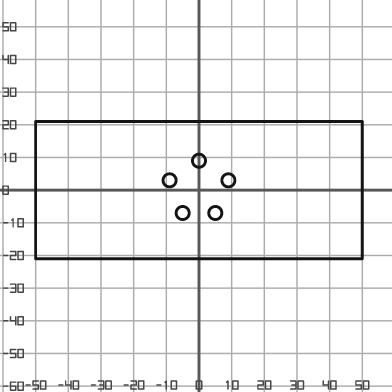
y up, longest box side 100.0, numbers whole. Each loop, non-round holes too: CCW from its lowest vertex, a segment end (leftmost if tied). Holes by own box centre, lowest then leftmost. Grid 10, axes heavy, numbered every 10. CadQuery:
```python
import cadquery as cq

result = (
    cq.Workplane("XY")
    .moveTo(-50.0, -21.0)
    .lineTo(50.0, -21.0)
    .lineTo(50.0, 21.0)
    .lineTo(-50.0, 21.0)
    .close()
    .moveTo(-5.0, -7.0)
    .circle(2.0)
    .moveTo(5.0, -7.0)
    .circle(2.0)
    .moveTo(-9.0, 3.0)
    .circle(2.0)
    .moveTo(9.0, 3.0)
    .circle(2.0)
    .moveTo(0.0, 9.0)
    .circle(2.0)
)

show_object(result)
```